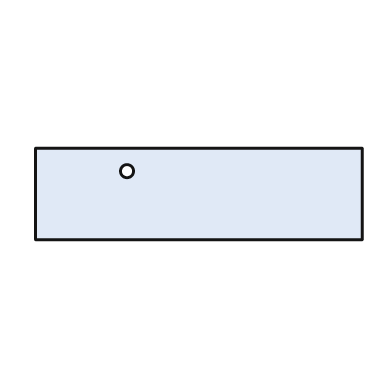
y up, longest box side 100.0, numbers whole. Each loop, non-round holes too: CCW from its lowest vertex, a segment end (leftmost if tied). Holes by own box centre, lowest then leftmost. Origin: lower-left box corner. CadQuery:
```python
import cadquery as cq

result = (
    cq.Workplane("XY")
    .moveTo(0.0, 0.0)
    .lineTo(100.0, 0.0)
    .lineTo(100.0, 28.0)
    .lineTo(0.0, 28.0)
    .close()
    .moveTo(28.0, 21.0)
    .circle(2.0)
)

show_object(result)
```